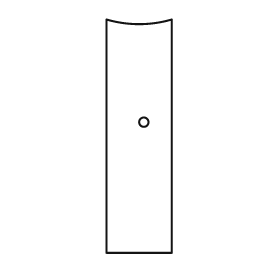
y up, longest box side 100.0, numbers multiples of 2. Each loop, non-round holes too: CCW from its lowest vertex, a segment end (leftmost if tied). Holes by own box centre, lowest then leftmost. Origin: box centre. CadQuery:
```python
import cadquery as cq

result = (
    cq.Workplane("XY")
    .moveTo(-14.0, -50.0)
    .lineTo(14.0, -50.0)
    .lineTo(14.0, 50.0)
    .threePointArc((0.0, 48.0), (-14.0, 50.0))
    .close()
    .moveTo(2.0, 6.0)
    .circle(2.0)
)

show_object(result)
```